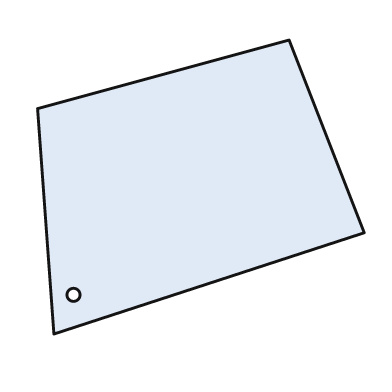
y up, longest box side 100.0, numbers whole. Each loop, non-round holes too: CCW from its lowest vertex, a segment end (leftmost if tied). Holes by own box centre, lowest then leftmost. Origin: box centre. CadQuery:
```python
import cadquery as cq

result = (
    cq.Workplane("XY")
    .moveTo(-45.0, -45.0)
    .lineTo(50.0, -14.0)
    .lineTo(27.0, 45.0)
    .lineTo(-50.0, 24.0)
    .close()
    .moveTo(-39.0, -33.0)
    .circle(2.0)
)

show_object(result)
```